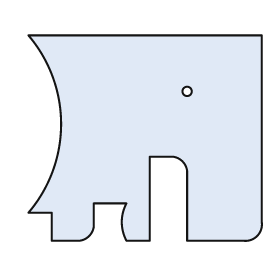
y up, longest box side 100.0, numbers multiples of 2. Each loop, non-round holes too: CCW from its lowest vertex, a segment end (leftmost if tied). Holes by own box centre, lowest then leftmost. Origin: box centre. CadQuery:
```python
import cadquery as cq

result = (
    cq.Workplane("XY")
    .moveTo(-40.0, -44.0)
    .lineTo(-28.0, -44.0)
    .threePointArc((-24.0, -42.0), (-22.0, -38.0))
    .lineTo(-22.0, -28.0)
    .lineTo(-8.0, -28.0)
    .threePointArc((-10.0, -36.0), (-8.0, -44.0))
    .lineTo(2.0, -44.0)
    .lineTo(2.0, -8.0)
    .lineTo(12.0, -8.0)
    .threePointArc((16.0, -10.0), (18.0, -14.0))
    .lineTo(18.0, -44.0)
    .lineTo(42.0, -44.0)
    .threePointArc((48.0, -42.0), (50.0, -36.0))
    .lineTo(50.0, 44.0)
    .lineTo(-50.0, 44.0)
    .threePointArc((-36.0, 6.0), (-50.0, -32.0))
    .lineTo(-40.0, -32.0)
    .close()
    .moveTo(18.0, 20.0)
    .circle(2.0)
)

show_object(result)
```